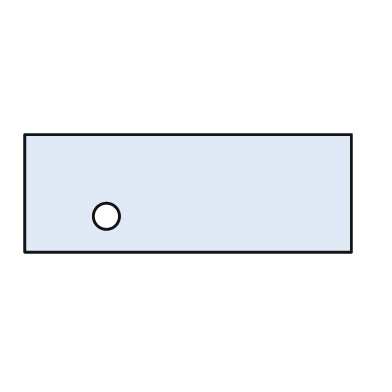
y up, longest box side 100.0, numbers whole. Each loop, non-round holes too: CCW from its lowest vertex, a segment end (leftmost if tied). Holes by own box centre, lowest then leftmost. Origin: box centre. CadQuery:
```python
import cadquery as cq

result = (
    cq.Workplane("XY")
    .moveTo(-50.0, -18.0)
    .lineTo(50.0, -18.0)
    .lineTo(50.0, 18.0)
    .lineTo(-50.0, 18.0)
    .close()
    .moveTo(-25.0, -7.0)
    .circle(4.0)
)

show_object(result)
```